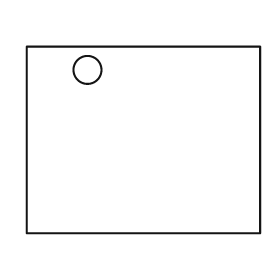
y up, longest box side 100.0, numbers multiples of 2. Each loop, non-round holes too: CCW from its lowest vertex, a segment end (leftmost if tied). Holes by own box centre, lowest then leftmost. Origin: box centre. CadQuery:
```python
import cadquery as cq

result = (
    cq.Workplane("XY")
    .moveTo(-50.0, -40.0)
    .lineTo(50.0, -40.0)
    .lineTo(50.0, 40.0)
    .lineTo(-50.0, 40.0)
    .close()
    .moveTo(-24.0, 30.0)
    .circle(6.0)
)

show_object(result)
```